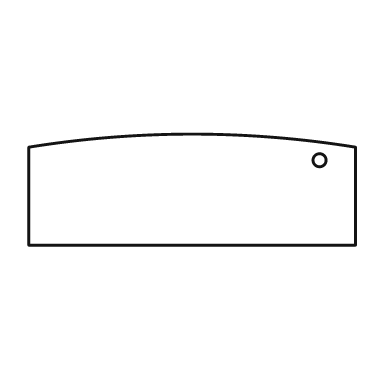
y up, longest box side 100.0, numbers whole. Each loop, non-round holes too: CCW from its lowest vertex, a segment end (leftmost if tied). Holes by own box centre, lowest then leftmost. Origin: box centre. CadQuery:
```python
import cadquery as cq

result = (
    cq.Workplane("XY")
    .moveTo(-50.0, -17.0)
    .lineTo(50.0, -17.0)
    .lineTo(50.0, 13.0)
    .threePointArc((0.0, 17.0), (-50.0, 13.0))
    .close()
    .moveTo(39.0, 9.0)
    .circle(2.0)
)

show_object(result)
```